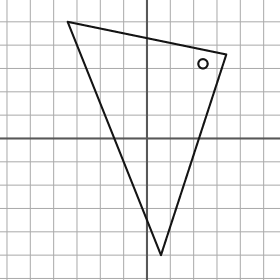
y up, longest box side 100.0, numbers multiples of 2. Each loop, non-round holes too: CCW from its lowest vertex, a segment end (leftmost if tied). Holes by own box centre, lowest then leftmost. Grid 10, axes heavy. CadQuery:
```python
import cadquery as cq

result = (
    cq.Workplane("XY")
    .moveTo(6.0, -50.0)
    .lineTo(34.0, 36.0)
    .lineTo(-34.0, 50.0)
    .close()
    .moveTo(24.0, 32.0)
    .circle(2.0)
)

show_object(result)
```